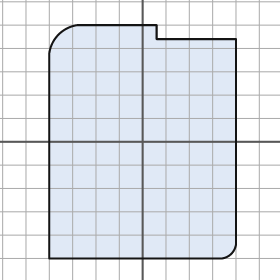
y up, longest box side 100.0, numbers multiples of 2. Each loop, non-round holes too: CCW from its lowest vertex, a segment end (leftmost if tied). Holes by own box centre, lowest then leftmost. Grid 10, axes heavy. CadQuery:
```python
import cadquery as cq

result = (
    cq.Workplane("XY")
    .moveTo(-40.0, -50.0)
    .lineTo(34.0, -50.0)
    .threePointArc((38.0, -48.0), (40.0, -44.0))
    .lineTo(40.0, 44.0)
    .lineTo(6.0, 44.0)
    .lineTo(6.0, 50.0)
    .lineTo(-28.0, 50.0)
    .threePointArc((-36.0, 46.0), (-40.0, 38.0))
    .close()
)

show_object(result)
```